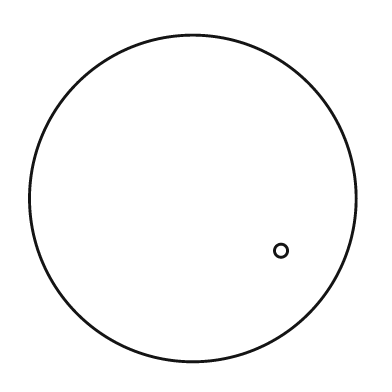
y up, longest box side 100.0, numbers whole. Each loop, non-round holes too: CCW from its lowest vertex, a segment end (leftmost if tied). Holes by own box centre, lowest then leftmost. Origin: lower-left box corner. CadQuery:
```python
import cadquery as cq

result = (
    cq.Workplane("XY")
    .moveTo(50.0, 50.0)
    .circle(50.0)
    .moveTo(77.0, 34.0)
    .circle(2.0)
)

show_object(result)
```